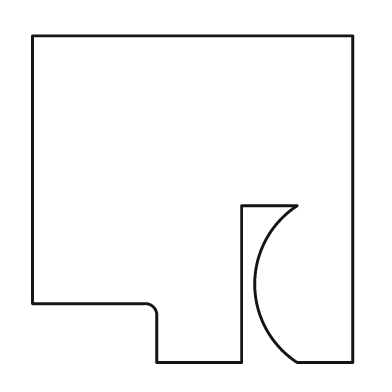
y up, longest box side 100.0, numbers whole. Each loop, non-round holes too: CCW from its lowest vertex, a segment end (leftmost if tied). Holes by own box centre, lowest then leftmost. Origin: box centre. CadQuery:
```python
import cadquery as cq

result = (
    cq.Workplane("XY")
    .moveTo(-11.0, -50.0)
    .lineTo(15.0, -50.0)
    .lineTo(15.0, -2.0)
    .lineTo(32.0, -2.0)
    .threePointArc((19.0, -26.0), (32.0, -50.0))
    .lineTo(49.0, -50.0)
    .lineTo(49.0, 50.0)
    .lineTo(-49.0, 50.0)
    .lineTo(-49.0, -32.0)
    .lineTo(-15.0, -32.0)
    .threePointArc((-12.0, -33.0), (-11.0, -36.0))
    .close()
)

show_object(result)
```